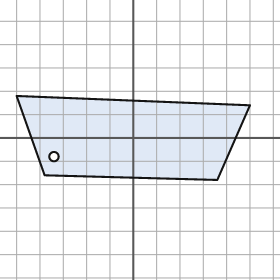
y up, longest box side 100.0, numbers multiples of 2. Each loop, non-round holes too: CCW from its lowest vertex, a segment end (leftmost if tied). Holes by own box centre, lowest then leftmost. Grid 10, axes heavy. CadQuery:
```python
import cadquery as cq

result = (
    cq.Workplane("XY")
    .moveTo(36.0, -18.0)
    .lineTo(50.0, 14.0)
    .lineTo(-50.0, 18.0)
    .lineTo(-38.0, -16.0)
    .close()
    .moveTo(-34.0, -8.0)
    .circle(2.0)
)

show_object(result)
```